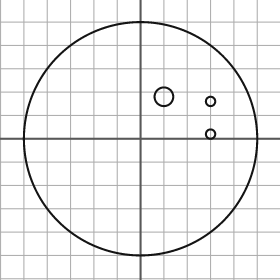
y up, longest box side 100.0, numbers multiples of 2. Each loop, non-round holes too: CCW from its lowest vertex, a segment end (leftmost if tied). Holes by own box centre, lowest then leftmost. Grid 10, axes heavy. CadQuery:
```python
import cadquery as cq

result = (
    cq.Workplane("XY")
    .moveTo(0.0, 0.0)
    .circle(50.0)
    .moveTo(30.0, 2.0)
    .circle(2.0)
    .moveTo(30.0, 16.0)
    .circle(2.0)
    .moveTo(10.0, 18.0)
    .circle(4.0)
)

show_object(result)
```